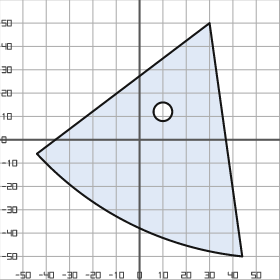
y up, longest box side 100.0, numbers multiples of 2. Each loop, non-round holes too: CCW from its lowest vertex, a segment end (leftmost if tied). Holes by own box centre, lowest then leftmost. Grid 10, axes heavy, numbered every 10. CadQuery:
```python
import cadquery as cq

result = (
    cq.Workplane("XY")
    .moveTo(44.0, -50.0)
    .lineTo(30.0, 50.0)
    .lineTo(-44.0, -6.0)
    .threePointArc((-4.0, -36.0), (44.0, -50.0))
    .close()
    .moveTo(10.0, 12.0)
    .circle(4.0)
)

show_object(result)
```